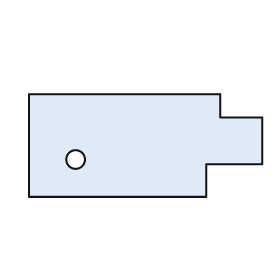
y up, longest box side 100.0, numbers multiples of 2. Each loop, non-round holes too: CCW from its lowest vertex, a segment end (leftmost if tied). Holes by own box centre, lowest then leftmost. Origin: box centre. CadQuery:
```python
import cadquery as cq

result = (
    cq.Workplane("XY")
    .moveTo(-50.0, -22.0)
    .lineTo(26.0, -22.0)
    .lineTo(26.0, -8.0)
    .lineTo(50.0, -8.0)
    .lineTo(50.0, 12.0)
    .lineTo(32.0, 12.0)
    .lineTo(32.0, 22.0)
    .lineTo(-50.0, 22.0)
    .close()
    .moveTo(-30.0, -6.0)
    .circle(4.0)
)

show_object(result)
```